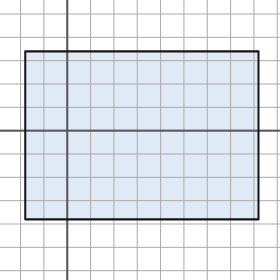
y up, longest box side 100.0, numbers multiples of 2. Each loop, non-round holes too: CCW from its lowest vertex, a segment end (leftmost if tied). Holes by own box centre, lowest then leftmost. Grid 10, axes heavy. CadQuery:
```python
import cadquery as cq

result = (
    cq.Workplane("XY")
    .moveTo(-18.0, -38.0)
    .lineTo(82.0, -38.0)
    .lineTo(82.0, 34.0)
    .lineTo(-18.0, 34.0)
    .close()
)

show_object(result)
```